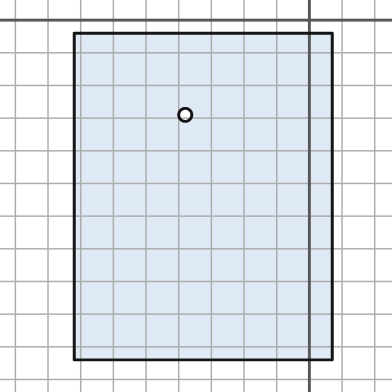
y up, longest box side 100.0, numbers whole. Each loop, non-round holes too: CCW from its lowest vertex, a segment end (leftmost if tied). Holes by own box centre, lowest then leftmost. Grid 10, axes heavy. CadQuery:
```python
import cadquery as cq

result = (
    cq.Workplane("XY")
    .moveTo(-72.0, -104.0)
    .lineTo(7.0, -104.0)
    .lineTo(7.0, -4.0)
    .lineTo(-72.0, -4.0)
    .close()
    .moveTo(-38.0, -29.0)
    .circle(2.0)
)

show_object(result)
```